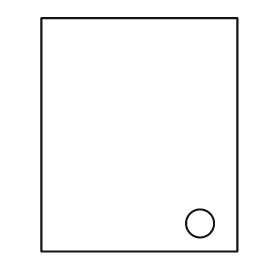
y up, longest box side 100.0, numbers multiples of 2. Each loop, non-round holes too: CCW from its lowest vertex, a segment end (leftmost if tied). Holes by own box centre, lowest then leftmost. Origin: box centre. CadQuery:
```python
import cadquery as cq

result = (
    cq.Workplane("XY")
    .moveTo(-42.0, -50.0)
    .lineTo(42.0, -50.0)
    .lineTo(42.0, 50.0)
    .lineTo(-42.0, 50.0)
    .close()
    .moveTo(26.0, -38.0)
    .circle(6.0)
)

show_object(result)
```